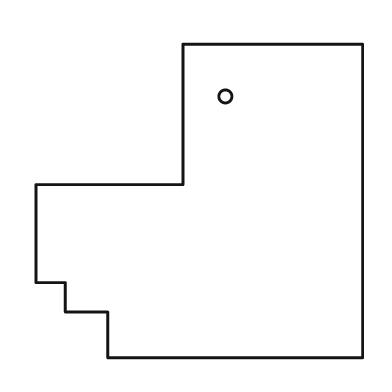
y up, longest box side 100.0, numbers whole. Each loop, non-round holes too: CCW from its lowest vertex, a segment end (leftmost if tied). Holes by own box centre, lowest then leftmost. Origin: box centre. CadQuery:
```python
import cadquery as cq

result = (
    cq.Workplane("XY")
    .moveTo(-28.0, -48.0)
    .lineTo(50.0, -48.0)
    .lineTo(50.0, 48.0)
    .lineTo(-5.0, 48.0)
    .lineTo(-5.0, 5.0)
    .lineTo(-50.0, 5.0)
    .lineTo(-50.0, -25.0)
    .lineTo(-41.0, -25.0)
    .lineTo(-41.0, -34.0)
    .lineTo(-28.0, -34.0)
    .close()
    .moveTo(8.0, 32.0)
    .circle(2.0)
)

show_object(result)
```